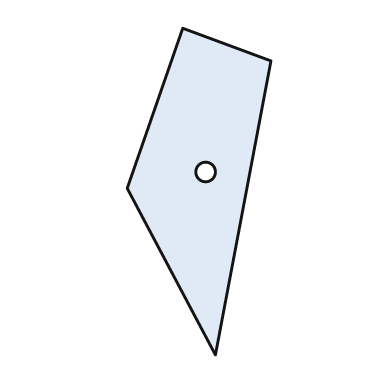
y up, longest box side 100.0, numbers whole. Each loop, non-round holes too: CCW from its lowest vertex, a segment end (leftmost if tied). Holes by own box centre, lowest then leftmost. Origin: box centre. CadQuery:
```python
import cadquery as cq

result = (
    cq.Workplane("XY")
    .moveTo(5.0, -50.0)
    .lineTo(22.0, 40.0)
    .lineTo(-5.0, 50.0)
    .lineTo(-22.0, 1.0)
    .close()
    .moveTo(2.0, 6.0)
    .circle(3.0)
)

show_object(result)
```